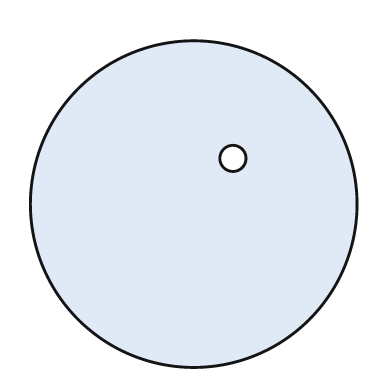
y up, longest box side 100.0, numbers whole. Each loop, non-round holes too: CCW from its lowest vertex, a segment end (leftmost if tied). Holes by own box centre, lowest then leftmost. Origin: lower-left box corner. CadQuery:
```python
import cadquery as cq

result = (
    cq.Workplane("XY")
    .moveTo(50.0, 50.0)
    .circle(50.0)
    .moveTo(62.0, 64.0)
    .circle(4.0)
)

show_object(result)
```